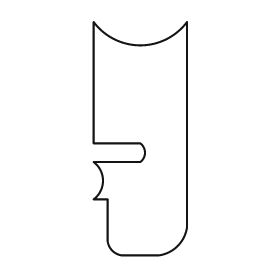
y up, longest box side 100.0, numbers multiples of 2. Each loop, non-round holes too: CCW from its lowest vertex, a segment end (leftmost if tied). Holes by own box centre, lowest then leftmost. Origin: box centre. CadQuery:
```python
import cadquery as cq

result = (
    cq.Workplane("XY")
    .moveTo(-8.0, -50.0)
    .lineTo(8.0, -50.0)
    .threePointArc((16.0, -46.0), (20.0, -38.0))
    .lineTo(20.0, 50.0)
    .threePointArc((0.0, 40.0), (-20.0, 50.0))
    .lineTo(-20.0, -2.0)
    .lineTo(0.0, -2.0)
    .threePointArc((2.0, -6.0), (0.0, -10.0))
    .lineTo(-20.0, -10.0)
    .threePointArc((-16.0, -18.0), (-20.0, -26.0))
    .lineTo(-14.0, -26.0)
    .lineTo(-14.0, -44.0)
    .threePointArc((-12.0, -48.0), (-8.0, -50.0))
    .close()
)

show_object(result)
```